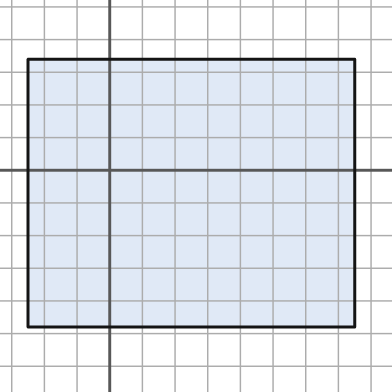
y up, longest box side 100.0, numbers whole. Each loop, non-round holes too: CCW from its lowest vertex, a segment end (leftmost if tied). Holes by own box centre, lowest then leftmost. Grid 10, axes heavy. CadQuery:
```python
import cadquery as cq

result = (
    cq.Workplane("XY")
    .moveTo(-25.0, -48.0)
    .lineTo(75.0, -48.0)
    .lineTo(75.0, 34.0)
    .lineTo(-25.0, 34.0)
    .close()
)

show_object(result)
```